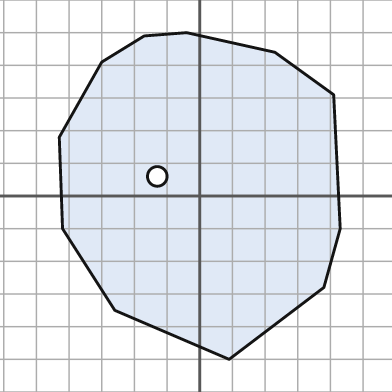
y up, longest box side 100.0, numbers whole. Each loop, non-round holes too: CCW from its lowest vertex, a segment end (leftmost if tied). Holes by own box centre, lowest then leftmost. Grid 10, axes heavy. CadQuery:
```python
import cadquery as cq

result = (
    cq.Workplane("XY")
    .moveTo(9.0, -50.0)
    .lineTo(38.0, -28.0)
    .lineTo(43.0, -10.0)
    .lineTo(41.0, 31.0)
    .lineTo(23.0, 44.0)
    .lineTo(-4.0, 50.0)
    .lineTo(-17.0, 49.0)
    .lineTo(-30.0, 41.0)
    .lineTo(-43.0, 18.0)
    .lineTo(-42.0, -10.0)
    .lineTo(-26.0, -35.0)
    .close()
    .moveTo(-13.0, 6.0)
    .circle(3.0)
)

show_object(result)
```